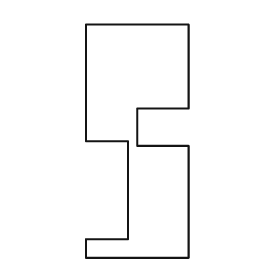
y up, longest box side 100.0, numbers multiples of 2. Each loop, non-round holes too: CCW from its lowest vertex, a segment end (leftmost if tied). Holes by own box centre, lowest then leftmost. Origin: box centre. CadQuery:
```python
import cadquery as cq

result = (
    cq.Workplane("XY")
    .moveTo(-22.0, -50.0)
    .lineTo(22.0, -50.0)
    .lineTo(22.0, -2.0)
    .lineTo(0.0, -2.0)
    .lineTo(0.0, 14.0)
    .lineTo(22.0, 14.0)
    .lineTo(22.0, 50.0)
    .lineTo(-22.0, 50.0)
    .lineTo(-22.0, 0.0)
    .lineTo(-4.0, 0.0)
    .lineTo(-4.0, -42.0)
    .lineTo(-22.0, -42.0)
    .close()
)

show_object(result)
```